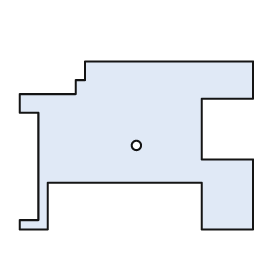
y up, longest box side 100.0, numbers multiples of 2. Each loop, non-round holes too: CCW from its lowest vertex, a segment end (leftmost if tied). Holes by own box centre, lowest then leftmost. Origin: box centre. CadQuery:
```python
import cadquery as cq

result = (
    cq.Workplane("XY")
    .moveTo(-50.0, -36.0)
    .lineTo(-38.0, -36.0)
    .lineTo(-38.0, -16.0)
    .lineTo(28.0, -16.0)
    .lineTo(28.0, -36.0)
    .lineTo(50.0, -36.0)
    .lineTo(50.0, -6.0)
    .lineTo(28.0, -6.0)
    .lineTo(28.0, 20.0)
    .lineTo(50.0, 20.0)
    .lineTo(50.0, 36.0)
    .lineTo(-22.0, 36.0)
    .lineTo(-22.0, 28.0)
    .lineTo(-26.0, 28.0)
    .lineTo(-26.0, 22.0)
    .lineTo(-50.0, 22.0)
    .lineTo(-50.0, 14.0)
    .lineTo(-42.0, 14.0)
    .lineTo(-42.0, -32.0)
    .lineTo(-50.0, -32.0)
    .close()
    .moveTo(0.0, 0.0)
    .circle(2.0)
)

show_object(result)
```